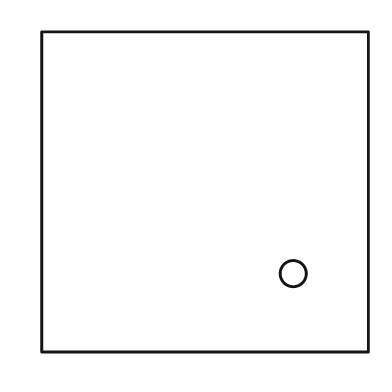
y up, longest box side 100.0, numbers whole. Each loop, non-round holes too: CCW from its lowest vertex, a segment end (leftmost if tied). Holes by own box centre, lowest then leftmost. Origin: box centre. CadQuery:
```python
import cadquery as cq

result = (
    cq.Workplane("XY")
    .moveTo(-50.0, -49.0)
    .lineTo(50.0, -49.0)
    .lineTo(50.0, 49.0)
    .lineTo(-50.0, 49.0)
    .close()
    .moveTo(27.0, -25.0)
    .circle(4.0)
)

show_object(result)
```